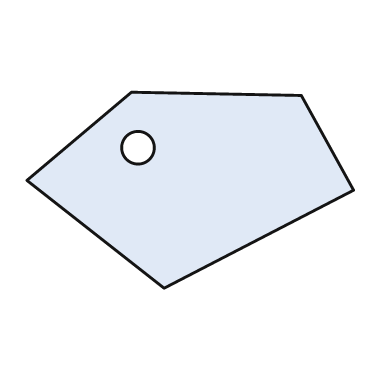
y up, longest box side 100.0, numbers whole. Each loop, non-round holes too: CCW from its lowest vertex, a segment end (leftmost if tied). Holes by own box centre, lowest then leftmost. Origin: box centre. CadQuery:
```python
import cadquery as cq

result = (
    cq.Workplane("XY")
    .moveTo(-8.0, -30.0)
    .lineTo(50.0, 0.0)
    .lineTo(34.0, 29.0)
    .lineTo(-18.0, 30.0)
    .lineTo(-50.0, 3.0)
    .close()
    .moveTo(-16.0, 13.0)
    .circle(5.0)
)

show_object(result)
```